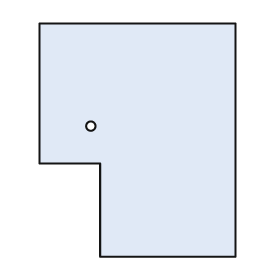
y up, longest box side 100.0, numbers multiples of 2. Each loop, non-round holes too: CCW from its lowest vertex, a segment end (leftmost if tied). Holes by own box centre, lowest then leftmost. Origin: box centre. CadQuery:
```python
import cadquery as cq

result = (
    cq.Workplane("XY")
    .moveTo(-16.0, -50.0)
    .lineTo(42.0, -50.0)
    .lineTo(42.0, 50.0)
    .lineTo(-42.0, 50.0)
    .lineTo(-42.0, -10.0)
    .lineTo(-16.0, -10.0)
    .close()
    .moveTo(-20.0, 6.0)
    .circle(2.0)
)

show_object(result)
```